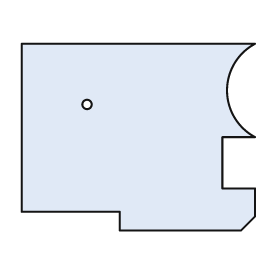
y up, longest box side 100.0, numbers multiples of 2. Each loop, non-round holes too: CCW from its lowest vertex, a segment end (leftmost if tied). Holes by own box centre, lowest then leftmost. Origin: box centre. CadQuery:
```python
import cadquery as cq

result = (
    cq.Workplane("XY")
    .moveTo(-8.0, -40.0)
    .lineTo(44.0, -40.0)
    .lineTo(50.0, -34.0)
    .lineTo(50.0, -22.0)
    .lineTo(36.0, -22.0)
    .lineTo(36.0, 0.0)
    .lineTo(50.0, 0.0)
    .threePointArc((38.0, 20.0), (50.0, 40.0))
    .lineTo(-50.0, 40.0)
    .lineTo(-50.0, -32.0)
    .lineTo(-8.0, -32.0)
    .close()
    .moveTo(-22.0, 14.0)
    .circle(2.0)
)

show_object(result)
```